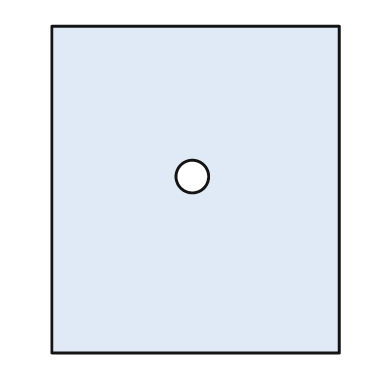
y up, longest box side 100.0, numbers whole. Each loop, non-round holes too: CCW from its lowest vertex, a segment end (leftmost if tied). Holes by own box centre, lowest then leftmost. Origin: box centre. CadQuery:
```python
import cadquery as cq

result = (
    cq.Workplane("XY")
    .moveTo(-44.0, -50.0)
    .lineTo(44.0, -50.0)
    .lineTo(44.0, 50.0)
    .lineTo(-44.0, 50.0)
    .close()
    .moveTo(-1.0, 4.0)
    .circle(5.0)
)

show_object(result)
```